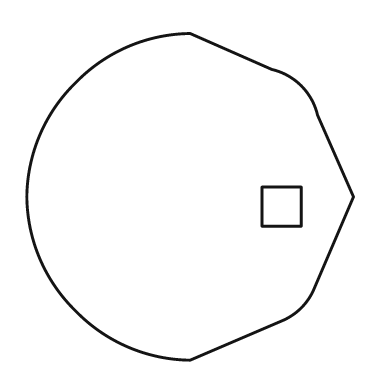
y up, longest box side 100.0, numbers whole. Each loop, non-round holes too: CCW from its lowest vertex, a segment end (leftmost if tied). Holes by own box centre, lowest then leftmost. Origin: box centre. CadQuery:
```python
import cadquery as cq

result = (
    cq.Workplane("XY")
    .moveTo(0.0, -50.0)
    .lineTo(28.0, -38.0)
    .threePointArc((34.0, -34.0), (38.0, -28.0))
    .lineTo(50.0, 0.0)
    .lineTo(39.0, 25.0)
    .threePointArc((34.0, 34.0), (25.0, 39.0))
    .lineTo(0.0, 50.0)
    .threePointArc((-19.0, 46.0), (-35.0, 35.0))
    .threePointArc((-46.0, 19.0), (-50.0, 0.0))
    .threePointArc((-46.0, -19.0), (-35.0, -35.0))
    .threePointArc((-19.0, -46.0), (0.0, -50.0))
    .close()
    .moveTo(22.0, -9.0)
    .lineTo(34.0, -9.0)
    .lineTo(34.0, 3.0)
    .lineTo(22.0, 3.0)
    .close()
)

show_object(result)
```